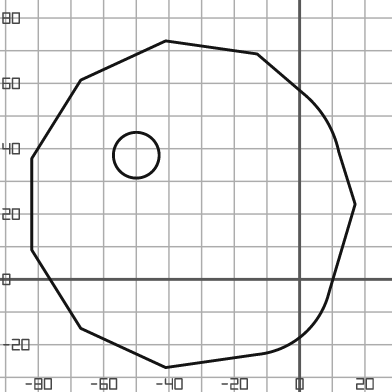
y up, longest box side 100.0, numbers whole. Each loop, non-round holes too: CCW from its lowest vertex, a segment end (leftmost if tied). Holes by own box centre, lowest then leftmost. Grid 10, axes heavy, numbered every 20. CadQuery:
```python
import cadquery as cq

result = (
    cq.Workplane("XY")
    .moveTo(-41.0, -27.0)
    .lineTo(-13.0, -23.0)
    .threePointArc((1.0, -17.0), (9.0, -4.0))
    .lineTo(17.0, 23.0)
    .lineTo(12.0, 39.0)
    .threePointArc((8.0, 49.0), (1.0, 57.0))
    .lineTo(-13.0, 69.0)
    .lineTo(-41.0, 73.0)
    .lineTo(-67.0, 61.0)
    .lineTo(-82.0, 37.0)
    .lineTo(-82.0, 9.0)
    .lineTo(-67.0, -15.0)
    .close()
    .moveTo(-50.0, 38.0)
    .circle(7.0)
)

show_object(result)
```